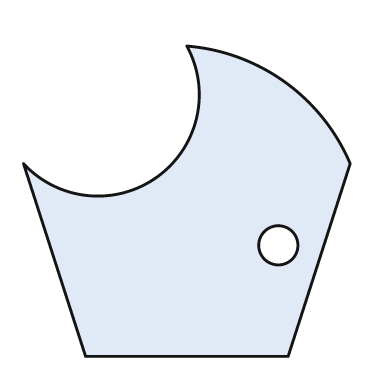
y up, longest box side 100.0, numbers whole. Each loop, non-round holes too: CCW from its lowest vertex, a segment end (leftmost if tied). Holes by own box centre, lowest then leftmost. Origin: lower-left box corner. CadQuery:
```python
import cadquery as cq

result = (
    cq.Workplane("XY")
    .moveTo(19.0, 0.0)
    .lineTo(81.0, 0.0)
    .lineTo(100.0, 59.0)
    .threePointArc((80.0, 84.0), (50.0, 95.0))
    .threePointArc((41.0, 55.0), (0.0, 59.0))
    .close()
    .moveTo(78.0, 34.0)
    .circle(6.0)
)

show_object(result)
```